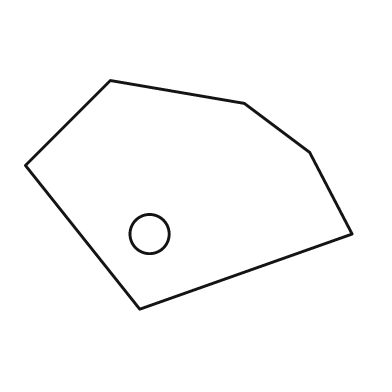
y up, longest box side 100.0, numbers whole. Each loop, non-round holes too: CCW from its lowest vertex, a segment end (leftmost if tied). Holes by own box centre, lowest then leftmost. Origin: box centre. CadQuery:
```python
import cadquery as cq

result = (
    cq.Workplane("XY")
    .moveTo(-15.0, -35.0)
    .lineTo(50.0, -12.0)
    .lineTo(37.0, 13.0)
    .lineTo(17.0, 28.0)
    .lineTo(-24.0, 35.0)
    .lineTo(-50.0, 9.0)
    .close()
    .moveTo(-12.0, -12.0)
    .circle(6.0)
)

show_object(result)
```